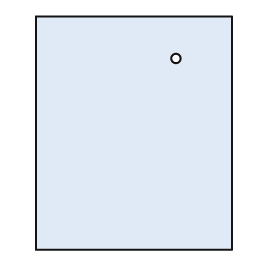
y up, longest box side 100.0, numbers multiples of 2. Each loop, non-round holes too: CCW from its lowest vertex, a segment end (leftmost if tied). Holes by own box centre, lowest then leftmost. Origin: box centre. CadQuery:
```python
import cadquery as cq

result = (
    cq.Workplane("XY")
    .moveTo(-42.0, -50.0)
    .lineTo(42.0, -50.0)
    .lineTo(42.0, 50.0)
    .lineTo(-42.0, 50.0)
    .close()
    .moveTo(18.0, 32.0)
    .circle(2.0)
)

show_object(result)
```